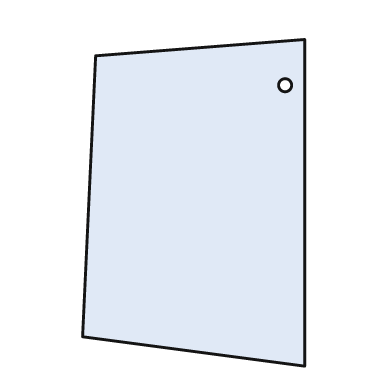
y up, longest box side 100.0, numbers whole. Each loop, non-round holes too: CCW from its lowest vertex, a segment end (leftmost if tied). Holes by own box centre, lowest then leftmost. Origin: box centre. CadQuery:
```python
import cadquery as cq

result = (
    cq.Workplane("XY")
    .moveTo(34.0, -50.0)
    .lineTo(34.0, 50.0)
    .lineTo(-30.0, 45.0)
    .lineTo(-34.0, -41.0)
    .close()
    .moveTo(28.0, 36.0)
    .circle(2.0)
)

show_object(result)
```